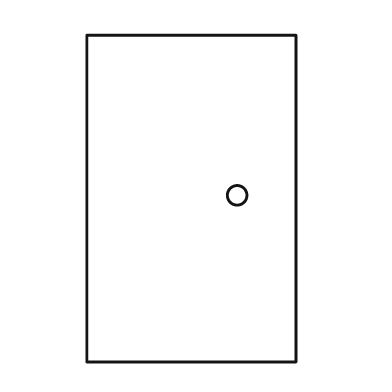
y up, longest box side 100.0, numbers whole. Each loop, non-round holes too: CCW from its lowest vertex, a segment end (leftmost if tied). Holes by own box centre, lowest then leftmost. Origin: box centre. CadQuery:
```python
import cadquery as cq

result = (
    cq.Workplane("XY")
    .moveTo(-32.0, -50.0)
    .lineTo(32.0, -50.0)
    .lineTo(32.0, 50.0)
    .lineTo(-32.0, 50.0)
    .close()
    .moveTo(14.0, 1.0)
    .circle(3.0)
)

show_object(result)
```